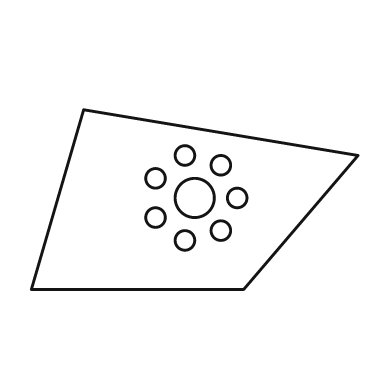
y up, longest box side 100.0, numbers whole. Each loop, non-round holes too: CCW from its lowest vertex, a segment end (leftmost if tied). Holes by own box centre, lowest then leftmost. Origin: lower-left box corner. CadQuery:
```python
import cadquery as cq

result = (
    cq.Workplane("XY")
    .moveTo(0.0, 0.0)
    .lineTo(65.0, 0.0)
    .lineTo(100.0, 41.0)
    .lineTo(16.0, 55.0)
    .close()
    .moveTo(47.0, 15.0)
    .circle(3.0)
    .moveTo(58.0, 18.0)
    .circle(3.0)
    .moveTo(38.0, 22.0)
    .circle(3.0)
    .moveTo(50.0, 28.0)
    .circle(6.0)
    .moveTo(63.0, 28.0)
    .circle(3.0)
    .moveTo(38.0, 34.0)
    .circle(3.0)
    .moveTo(58.0, 38.0)
    .circle(3.0)
    .moveTo(47.0, 41.0)
    .circle(3.0)
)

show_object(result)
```